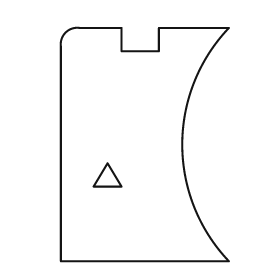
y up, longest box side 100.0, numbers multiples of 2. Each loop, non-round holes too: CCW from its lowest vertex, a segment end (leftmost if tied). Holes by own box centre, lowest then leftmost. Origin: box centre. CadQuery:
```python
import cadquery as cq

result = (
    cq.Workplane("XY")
    .moveTo(-36.0, -50.0)
    .lineTo(36.0, -50.0)
    .threePointArc((16.0, 0.0), (36.0, 50.0))
    .lineTo(6.0, 50.0)
    .lineTo(6.0, 40.0)
    .lineTo(-10.0, 40.0)
    .lineTo(-10.0, 50.0)
    .lineTo(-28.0, 50.0)
    .threePointArc((-34.0, 48.0), (-36.0, 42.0))
    .close()
    .moveTo(-22.0, -18.0)
    .lineTo(-10.0, -18.0)
    .lineTo(-16.0, -8.0)
    .close()
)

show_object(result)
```